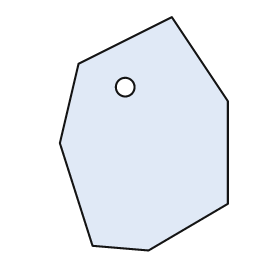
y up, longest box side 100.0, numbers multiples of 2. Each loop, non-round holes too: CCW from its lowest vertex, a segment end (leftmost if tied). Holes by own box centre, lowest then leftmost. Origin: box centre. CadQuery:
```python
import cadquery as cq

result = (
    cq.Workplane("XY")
    .moveTo(2.0, -50.0)
    .lineTo(36.0, -30.0)
    .lineTo(36.0, 14.0)
    .lineTo(12.0, 50.0)
    .lineTo(-28.0, 30.0)
    .lineTo(-36.0, -4.0)
    .lineTo(-22.0, -48.0)
    .close()
    .moveTo(-8.0, 20.0)
    .circle(4.0)
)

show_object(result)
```